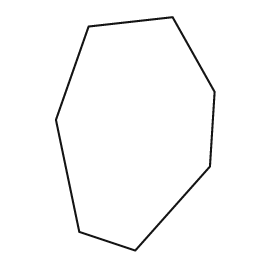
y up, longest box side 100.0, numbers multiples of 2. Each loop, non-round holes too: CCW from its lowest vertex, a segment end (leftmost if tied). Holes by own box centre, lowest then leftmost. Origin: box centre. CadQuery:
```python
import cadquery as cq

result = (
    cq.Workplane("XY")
    .moveTo(0.0, -50.0)
    .lineTo(32.0, -14.0)
    .lineTo(34.0, 18.0)
    .lineTo(16.0, 50.0)
    .lineTo(-20.0, 46.0)
    .lineTo(-34.0, 6.0)
    .lineTo(-24.0, -42.0)
    .close()
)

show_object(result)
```